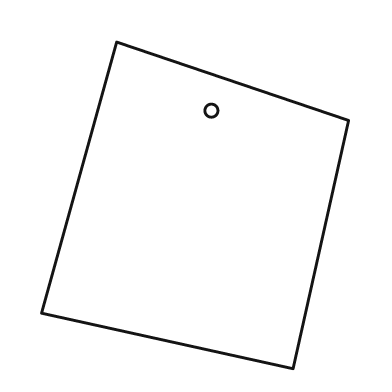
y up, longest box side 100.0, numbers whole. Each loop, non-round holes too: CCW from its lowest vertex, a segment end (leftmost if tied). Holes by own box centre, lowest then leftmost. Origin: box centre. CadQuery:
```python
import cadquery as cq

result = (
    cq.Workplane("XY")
    .moveTo(30.0, -50.0)
    .lineTo(47.0, 26.0)
    .lineTo(-24.0, 50.0)
    .lineTo(-47.0, -33.0)
    .close()
    .moveTo(5.0, 29.0)
    .circle(2.0)
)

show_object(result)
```